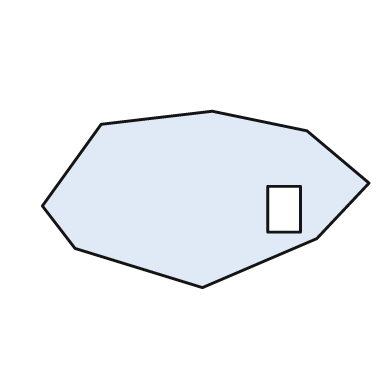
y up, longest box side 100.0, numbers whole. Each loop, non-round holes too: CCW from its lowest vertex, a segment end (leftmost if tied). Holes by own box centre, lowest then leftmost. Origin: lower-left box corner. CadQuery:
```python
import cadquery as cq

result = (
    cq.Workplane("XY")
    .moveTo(49.0, 0.0)
    .lineTo(84.0, 15.0)
    .lineTo(100.0, 32.0)
    .lineTo(81.0, 48.0)
    .lineTo(52.0, 54.0)
    .lineTo(18.0, 50.0)
    .lineTo(0.0, 25.0)
    .lineTo(10.0, 12.0)
    .close()
    .moveTo(69.0, 17.0)
    .lineTo(79.0, 17.0)
    .lineTo(79.0, 31.0)
    .lineTo(69.0, 31.0)
    .close()
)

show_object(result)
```